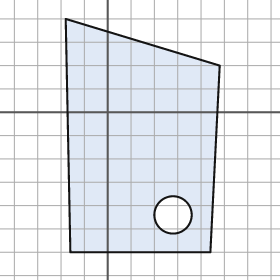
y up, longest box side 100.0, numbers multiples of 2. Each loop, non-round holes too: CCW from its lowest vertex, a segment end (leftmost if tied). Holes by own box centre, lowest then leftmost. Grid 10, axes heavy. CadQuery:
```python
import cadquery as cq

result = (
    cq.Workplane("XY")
    .moveTo(-16.0, -60.0)
    .lineTo(44.0, -60.0)
    .lineTo(48.0, 20.0)
    .lineTo(-18.0, 40.0)
    .close()
    .moveTo(28.0, -44.0)
    .circle(8.0)
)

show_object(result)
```